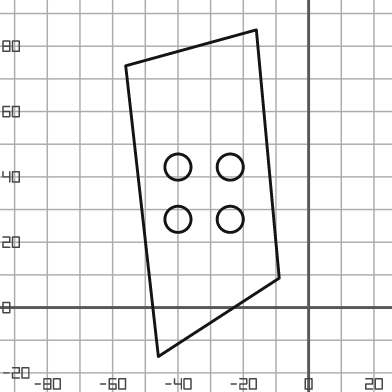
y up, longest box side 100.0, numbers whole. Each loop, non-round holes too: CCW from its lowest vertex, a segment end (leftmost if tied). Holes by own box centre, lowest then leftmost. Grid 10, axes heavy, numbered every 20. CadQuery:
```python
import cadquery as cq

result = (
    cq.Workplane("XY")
    .moveTo(-46.0, -15.0)
    .lineTo(-9.0, 9.0)
    .lineTo(-16.0, 85.0)
    .lineTo(-56.0, 74.0)
    .close()
    .moveTo(-40.0, 27.0)
    .circle(4.0)
    .moveTo(-24.0, 27.0)
    .circle(4.0)
    .moveTo(-40.0, 43.0)
    .circle(4.0)
    .moveTo(-24.0, 43.0)
    .circle(4.0)
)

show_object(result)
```